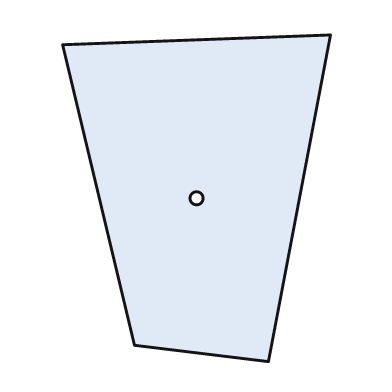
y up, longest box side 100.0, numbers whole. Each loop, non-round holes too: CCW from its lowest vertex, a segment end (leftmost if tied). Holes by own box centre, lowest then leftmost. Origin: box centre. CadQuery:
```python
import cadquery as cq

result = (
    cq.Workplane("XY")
    .moveTo(22.0, -50.0)
    .lineTo(41.0, 50.0)
    .lineTo(-41.0, 47.0)
    .lineTo(-19.0, -45.0)
    .close()
    .moveTo(0.0, 0.0)
    .circle(2.0)
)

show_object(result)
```